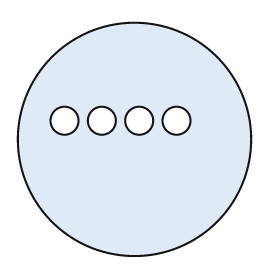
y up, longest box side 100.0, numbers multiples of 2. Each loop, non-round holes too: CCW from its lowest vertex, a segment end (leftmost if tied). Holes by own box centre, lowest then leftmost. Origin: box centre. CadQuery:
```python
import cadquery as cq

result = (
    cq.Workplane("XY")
    .moveTo(0.0, 0.0)
    .circle(50.0)
    .moveTo(-30.0, 8.0)
    .circle(6.0)
    .moveTo(-14.0, 8.0)
    .circle(6.0)
    .moveTo(2.0, 8.0)
    .circle(6.0)
    .moveTo(18.0, 8.0)
    .circle(6.0)
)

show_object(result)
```